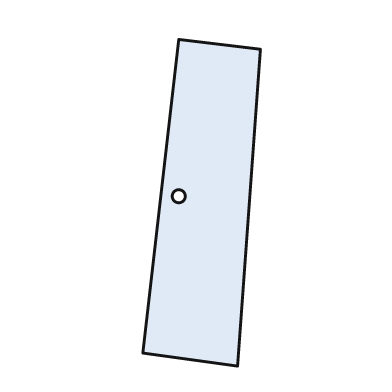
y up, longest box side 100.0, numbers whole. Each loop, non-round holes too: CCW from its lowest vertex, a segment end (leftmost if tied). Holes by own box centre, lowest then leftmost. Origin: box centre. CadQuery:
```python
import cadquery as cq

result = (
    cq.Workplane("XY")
    .moveTo(11.0, -50.0)
    .lineTo(18.0, 47.0)
    .lineTo(-7.0, 50.0)
    .lineTo(-18.0, -46.0)
    .close()
    .moveTo(-7.0, 2.0)
    .circle(2.0)
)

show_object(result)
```